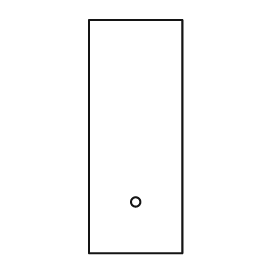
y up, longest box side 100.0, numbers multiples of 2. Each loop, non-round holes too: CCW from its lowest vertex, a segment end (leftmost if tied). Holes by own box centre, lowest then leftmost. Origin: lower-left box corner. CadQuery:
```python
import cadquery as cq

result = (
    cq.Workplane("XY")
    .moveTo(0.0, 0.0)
    .lineTo(40.0, 0.0)
    .lineTo(40.0, 100.0)
    .lineTo(0.0, 100.0)
    .close()
    .moveTo(20.0, 22.0)
    .circle(2.0)
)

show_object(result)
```